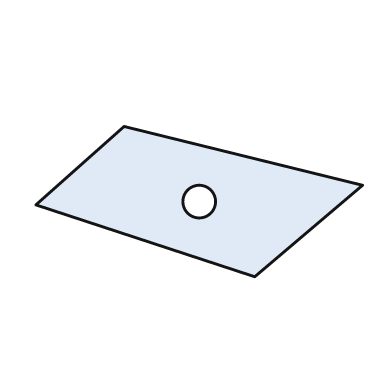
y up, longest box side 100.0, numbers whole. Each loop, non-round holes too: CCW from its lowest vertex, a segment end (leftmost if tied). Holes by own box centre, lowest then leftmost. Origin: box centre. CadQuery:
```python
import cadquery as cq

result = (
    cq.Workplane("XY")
    .moveTo(17.0, -23.0)
    .lineTo(50.0, 5.0)
    .lineTo(-23.0, 23.0)
    .lineTo(-50.0, -1.0)
    .close()
    .moveTo(0.0, 0.0)
    .circle(5.0)
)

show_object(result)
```